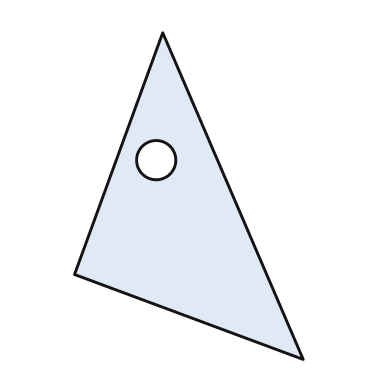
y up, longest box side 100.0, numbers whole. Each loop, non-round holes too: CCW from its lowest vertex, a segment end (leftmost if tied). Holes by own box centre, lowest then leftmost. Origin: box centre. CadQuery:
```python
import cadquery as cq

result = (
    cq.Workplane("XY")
    .moveTo(35.0, -50.0)
    .lineTo(-8.0, 50.0)
    .lineTo(-35.0, -24.0)
    .close()
    .moveTo(-10.0, 11.0)
    .circle(6.0)
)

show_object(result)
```